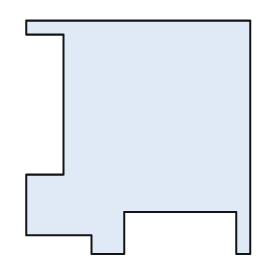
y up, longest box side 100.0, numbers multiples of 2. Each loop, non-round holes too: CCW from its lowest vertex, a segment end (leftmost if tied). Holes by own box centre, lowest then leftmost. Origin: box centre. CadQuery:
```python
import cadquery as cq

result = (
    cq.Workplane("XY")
    .moveTo(-20.0, -50.0)
    .lineTo(-6.0, -50.0)
    .lineTo(-6.0, -32.0)
    .lineTo(42.0, -32.0)
    .lineTo(42.0, -50.0)
    .lineTo(48.0, -50.0)
    .lineTo(48.0, 50.0)
    .lineTo(-48.0, 50.0)
    .lineTo(-48.0, 44.0)
    .lineTo(-32.0, 44.0)
    .lineTo(-32.0, -16.0)
    .lineTo(-48.0, -16.0)
    .lineTo(-48.0, -42.0)
    .lineTo(-20.0, -42.0)
    .close()
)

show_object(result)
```